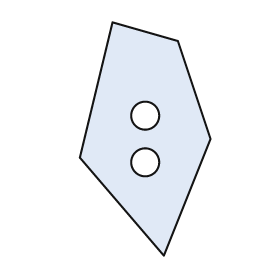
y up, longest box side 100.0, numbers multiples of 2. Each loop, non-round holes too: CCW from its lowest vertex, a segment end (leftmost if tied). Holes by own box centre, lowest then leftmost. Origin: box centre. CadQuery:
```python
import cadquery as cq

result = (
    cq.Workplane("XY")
    .moveTo(8.0, -50.0)
    .lineTo(28.0, 0.0)
    .lineTo(14.0, 42.0)
    .lineTo(-14.0, 50.0)
    .lineTo(-28.0, -8.0)
    .close()
    .moveTo(0.0, -10.0)
    .circle(6.0)
    .moveTo(0.0, 10.0)
    .circle(6.0)
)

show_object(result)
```